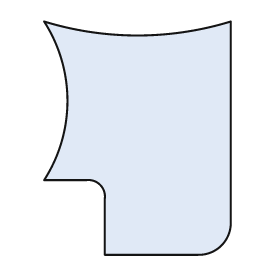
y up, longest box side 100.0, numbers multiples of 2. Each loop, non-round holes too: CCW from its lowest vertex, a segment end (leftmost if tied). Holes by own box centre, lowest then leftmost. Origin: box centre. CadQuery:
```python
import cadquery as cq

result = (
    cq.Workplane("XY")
    .moveTo(-14.0, -50.0)
    .lineTo(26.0, -50.0)
    .threePointArc((36.0, -46.0), (40.0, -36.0))
    .lineTo(40.0, 50.0)
    .threePointArc((0.0, 44.0), (-40.0, 50.0))
    .threePointArc((-30.0, 16.0), (-40.0, -18.0))
    .lineTo(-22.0, -18.0)
    .threePointArc((-16.0, -20.0), (-14.0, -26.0))
    .close()
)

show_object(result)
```